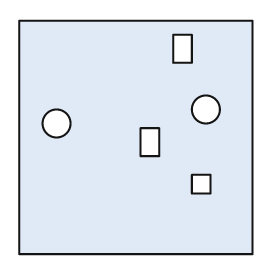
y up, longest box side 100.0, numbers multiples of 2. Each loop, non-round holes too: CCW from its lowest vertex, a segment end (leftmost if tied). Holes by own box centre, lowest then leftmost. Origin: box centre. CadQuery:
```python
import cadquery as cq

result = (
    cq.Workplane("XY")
    .moveTo(-50.0, -50.0)
    .lineTo(50.0, -50.0)
    .lineTo(50.0, 50.0)
    .lineTo(-50.0, 50.0)
    .close()
    .moveTo(24.0, -24.0)
    .lineTo(32.0, -24.0)
    .lineTo(32.0, -16.0)
    .lineTo(24.0, -16.0)
    .close()
    .moveTo(2.0, -8.0)
    .lineTo(10.0, -8.0)
    .lineTo(10.0, 4.0)
    .lineTo(2.0, 4.0)
    .close()
    .moveTo(-34.0, 6.0)
    .circle(6.0)
    .moveTo(30.0, 12.0)
    .circle(6.0)
    .moveTo(16.0, 32.0)
    .lineTo(24.0, 32.0)
    .lineTo(24.0, 44.0)
    .lineTo(16.0, 44.0)
    .close()
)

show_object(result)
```